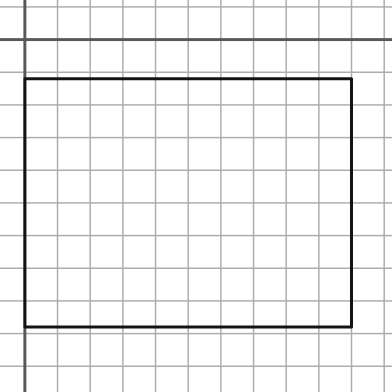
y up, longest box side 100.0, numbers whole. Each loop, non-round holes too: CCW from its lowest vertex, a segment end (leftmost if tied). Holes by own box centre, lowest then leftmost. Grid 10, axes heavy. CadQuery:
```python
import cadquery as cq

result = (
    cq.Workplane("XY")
    .moveTo(0.0, -88.0)
    .lineTo(100.0, -88.0)
    .lineTo(100.0, -12.0)
    .lineTo(0.0, -12.0)
    .close()
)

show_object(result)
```